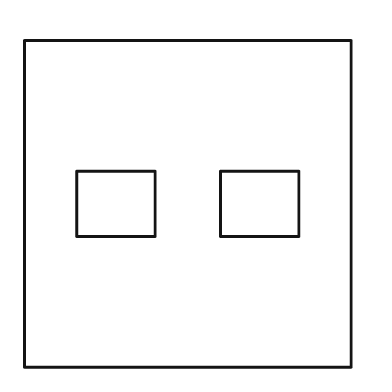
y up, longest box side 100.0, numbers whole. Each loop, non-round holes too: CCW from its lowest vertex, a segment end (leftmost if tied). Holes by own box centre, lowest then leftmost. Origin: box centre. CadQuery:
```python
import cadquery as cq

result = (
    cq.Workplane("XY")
    .moveTo(-50.0, -50.0)
    .lineTo(50.0, -50.0)
    .lineTo(50.0, 50.0)
    .lineTo(-50.0, 50.0)
    .close()
    .moveTo(-34.0, -10.0)
    .lineTo(-10.0, -10.0)
    .lineTo(-10.0, 10.0)
    .lineTo(-34.0, 10.0)
    .close()
    .moveTo(10.0, -10.0)
    .lineTo(34.0, -10.0)
    .lineTo(34.0, 10.0)
    .lineTo(10.0, 10.0)
    .close()
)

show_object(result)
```